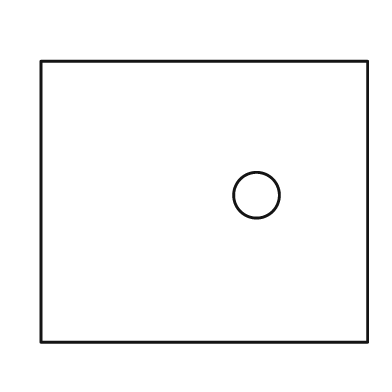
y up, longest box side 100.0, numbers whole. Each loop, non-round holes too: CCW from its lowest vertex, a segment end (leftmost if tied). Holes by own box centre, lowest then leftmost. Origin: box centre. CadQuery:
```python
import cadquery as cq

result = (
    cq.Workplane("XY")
    .moveTo(-50.0, -43.0)
    .lineTo(50.0, -43.0)
    .lineTo(50.0, 43.0)
    .lineTo(-50.0, 43.0)
    .close()
    .moveTo(16.0, 2.0)
    .circle(7.0)
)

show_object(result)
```